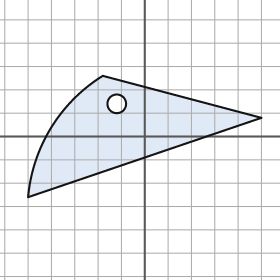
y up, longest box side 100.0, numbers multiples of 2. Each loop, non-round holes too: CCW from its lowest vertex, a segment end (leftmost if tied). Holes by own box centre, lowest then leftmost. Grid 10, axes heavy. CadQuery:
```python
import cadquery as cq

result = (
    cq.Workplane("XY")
    .moveTo(-50.0, -26.0)
    .lineTo(50.0, 8.0)
    .lineTo(-18.0, 26.0)
    .threePointArc((-40.0, 4.0), (-50.0, -26.0))
    .close()
    .moveTo(-12.0, 14.0)
    .circle(4.0)
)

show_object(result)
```